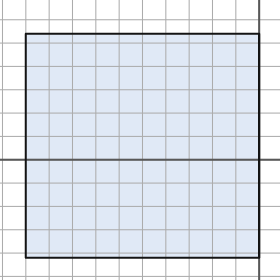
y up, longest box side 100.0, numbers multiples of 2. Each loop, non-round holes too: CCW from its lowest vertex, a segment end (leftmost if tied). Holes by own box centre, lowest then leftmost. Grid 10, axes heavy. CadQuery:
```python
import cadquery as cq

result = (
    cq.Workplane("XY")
    .moveTo(-100.0, -42.0)
    .lineTo(0.0, -42.0)
    .lineTo(0.0, 54.0)
    .lineTo(-100.0, 54.0)
    .close()
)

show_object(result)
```